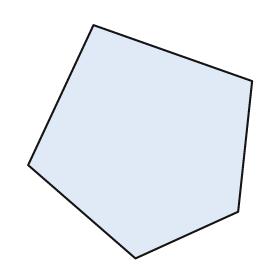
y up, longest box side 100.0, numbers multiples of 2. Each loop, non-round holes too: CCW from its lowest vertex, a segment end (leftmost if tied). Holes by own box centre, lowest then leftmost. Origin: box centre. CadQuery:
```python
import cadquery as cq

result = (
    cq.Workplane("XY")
    .moveTo(-2.0, -50.0)
    .lineTo(42.0, -30.0)
    .lineTo(48.0, 26.0)
    .lineTo(-20.0, 50.0)
    .lineTo(-48.0, -10.0)
    .close()
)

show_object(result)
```